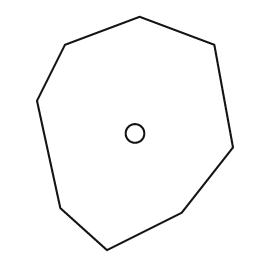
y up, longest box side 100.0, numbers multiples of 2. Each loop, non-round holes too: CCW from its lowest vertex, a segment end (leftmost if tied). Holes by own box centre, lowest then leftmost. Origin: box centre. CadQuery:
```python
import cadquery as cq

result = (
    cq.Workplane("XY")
    .moveTo(-12.0, -50.0)
    .lineTo(20.0, -34.0)
    .lineTo(42.0, -6.0)
    .lineTo(34.0, 38.0)
    .lineTo(2.0, 50.0)
    .lineTo(-30.0, 38.0)
    .lineTo(-42.0, 14.0)
    .lineTo(-32.0, -32.0)
    .close()
    .moveTo(0.0, 0.0)
    .circle(4.0)
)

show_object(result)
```